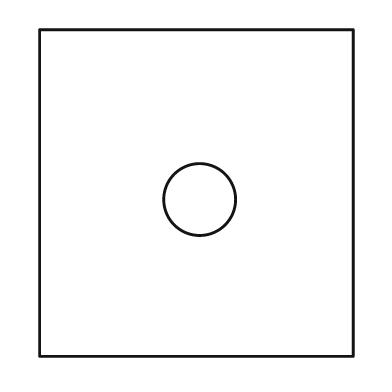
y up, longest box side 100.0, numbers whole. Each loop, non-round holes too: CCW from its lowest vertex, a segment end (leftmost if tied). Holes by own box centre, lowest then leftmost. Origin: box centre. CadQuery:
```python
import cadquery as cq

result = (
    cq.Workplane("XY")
    .moveTo(-48.0, -50.0)
    .lineTo(48.0, -50.0)
    .lineTo(48.0, 50.0)
    .lineTo(-48.0, 50.0)
    .close()
    .moveTo(1.0, -2.0)
    .circle(11.0)
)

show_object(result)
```